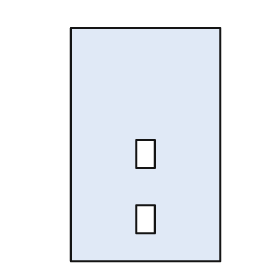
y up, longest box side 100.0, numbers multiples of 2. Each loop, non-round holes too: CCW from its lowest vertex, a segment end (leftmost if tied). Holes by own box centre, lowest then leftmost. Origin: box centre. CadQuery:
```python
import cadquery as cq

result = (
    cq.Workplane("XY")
    .moveTo(-32.0, -50.0)
    .lineTo(32.0, -50.0)
    .lineTo(32.0, 50.0)
    .lineTo(-32.0, 50.0)
    .close()
    .moveTo(-4.0, -38.0)
    .lineTo(4.0, -38.0)
    .lineTo(4.0, -26.0)
    .lineTo(-4.0, -26.0)
    .close()
    .moveTo(-4.0, -10.0)
    .lineTo(4.0, -10.0)
    .lineTo(4.0, 2.0)
    .lineTo(-4.0, 2.0)
    .close()
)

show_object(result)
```